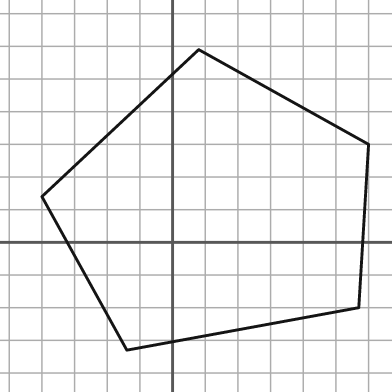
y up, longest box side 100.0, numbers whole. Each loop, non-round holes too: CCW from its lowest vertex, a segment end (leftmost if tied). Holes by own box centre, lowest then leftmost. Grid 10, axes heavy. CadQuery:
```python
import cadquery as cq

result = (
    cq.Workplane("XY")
    .moveTo(-14.0, -33.0)
    .lineTo(57.0, -20.0)
    .lineTo(60.0, 30.0)
    .lineTo(8.0, 59.0)
    .lineTo(-40.0, 14.0)
    .close()
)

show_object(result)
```